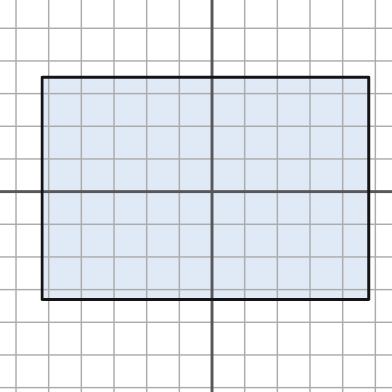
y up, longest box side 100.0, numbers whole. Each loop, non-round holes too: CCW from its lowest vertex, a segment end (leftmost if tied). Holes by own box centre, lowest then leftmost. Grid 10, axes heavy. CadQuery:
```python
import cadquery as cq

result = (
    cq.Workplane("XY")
    .moveTo(-52.0, -33.0)
    .lineTo(48.0, -33.0)
    .lineTo(48.0, 35.0)
    .lineTo(-52.0, 35.0)
    .close()
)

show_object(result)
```